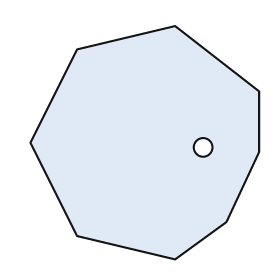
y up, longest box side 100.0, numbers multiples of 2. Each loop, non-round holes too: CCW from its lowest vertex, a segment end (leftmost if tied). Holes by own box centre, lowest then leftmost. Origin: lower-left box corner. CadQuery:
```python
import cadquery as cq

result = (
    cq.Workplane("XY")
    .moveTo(62.0, 0.0)
    .lineTo(84.0, 16.0)
    .lineTo(98.0, 46.0)
    .lineTo(98.0, 72.0)
    .lineTo(62.0, 100.0)
    .lineTo(20.0, 90.0)
    .lineTo(0.0, 50.0)
    .lineTo(20.0, 10.0)
    .close()
    .moveTo(74.0, 48.0)
    .circle(4.0)
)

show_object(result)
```